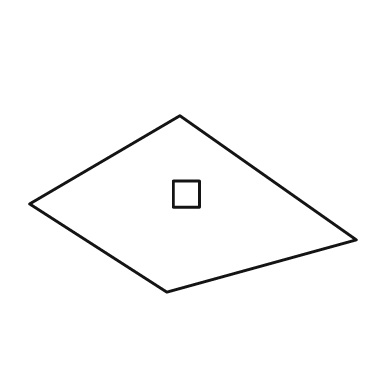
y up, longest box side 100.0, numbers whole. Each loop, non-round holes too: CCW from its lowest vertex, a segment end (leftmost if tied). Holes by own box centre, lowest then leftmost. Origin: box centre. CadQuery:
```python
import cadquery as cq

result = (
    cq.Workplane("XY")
    .moveTo(-8.0, -27.0)
    .lineTo(50.0, -11.0)
    .lineTo(-4.0, 27.0)
    .lineTo(-50.0, 0.0)
    .close()
    .moveTo(-6.0, -1.0)
    .lineTo(2.0, -1.0)
    .lineTo(2.0, 7.0)
    .lineTo(-6.0, 7.0)
    .close()
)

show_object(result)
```